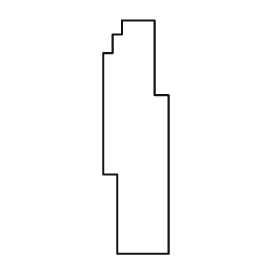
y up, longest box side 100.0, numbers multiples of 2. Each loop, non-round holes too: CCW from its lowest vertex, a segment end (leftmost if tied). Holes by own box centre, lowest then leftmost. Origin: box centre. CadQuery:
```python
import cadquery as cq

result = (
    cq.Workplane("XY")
    .moveTo(-8.0, -50.0)
    .lineTo(14.0, -50.0)
    .lineTo(14.0, 18.0)
    .lineTo(8.0, 18.0)
    .lineTo(8.0, 50.0)
    .lineTo(-6.0, 50.0)
    .lineTo(-6.0, 44.0)
    .lineTo(-10.0, 44.0)
    .lineTo(-10.0, 36.0)
    .lineTo(-14.0, 36.0)
    .lineTo(-14.0, -16.0)
    .lineTo(-8.0, -16.0)
    .close()
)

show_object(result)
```